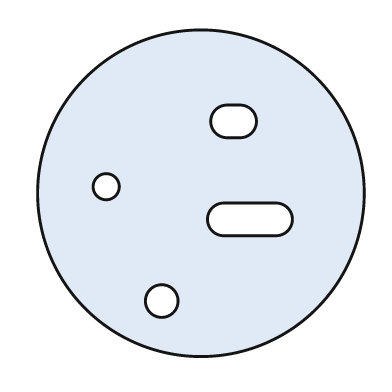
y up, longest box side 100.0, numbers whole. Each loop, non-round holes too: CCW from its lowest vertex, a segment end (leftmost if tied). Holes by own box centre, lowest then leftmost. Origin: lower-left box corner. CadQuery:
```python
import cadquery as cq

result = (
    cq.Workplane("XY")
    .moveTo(50.0, 50.0)
    .circle(50.0)
    .moveTo(38.0, 17.0)
    .circle(5.0)
    .moveTo(57.0, 37.0)
    .lineTo(73.0, 37.0)
    .threePointArc((78.0, 42.0), (73.0, 47.0))
    .lineTo(57.0, 47.0)
    .threePointArc((52.0, 42.0), (57.0, 37.0))
    .close()
    .moveTo(21.0, 52.0)
    .circle(4.0)
    .moveTo(58.0, 67.0)
    .lineTo(62.0, 67.0)
    .threePointArc((67.0, 72.0), (62.0, 77.0))
    .lineTo(58.0, 77.0)
    .threePointArc((53.0, 72.0), (58.0, 67.0))
    .close()
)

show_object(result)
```